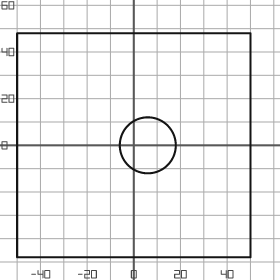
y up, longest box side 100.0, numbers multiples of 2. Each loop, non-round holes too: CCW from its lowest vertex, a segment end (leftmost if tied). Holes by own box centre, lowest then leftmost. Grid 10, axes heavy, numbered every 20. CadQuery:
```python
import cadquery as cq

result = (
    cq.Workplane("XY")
    .moveTo(-50.0, -48.0)
    .lineTo(50.0, -48.0)
    .lineTo(50.0, 48.0)
    .lineTo(-50.0, 48.0)
    .close()
    .moveTo(6.0, 0.0)
    .circle(12.0)
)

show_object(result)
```